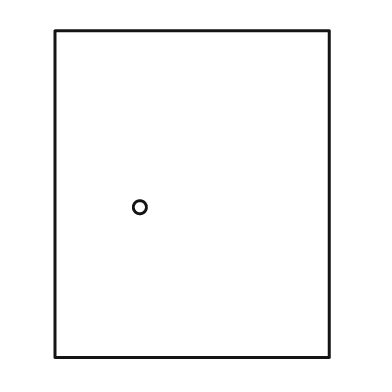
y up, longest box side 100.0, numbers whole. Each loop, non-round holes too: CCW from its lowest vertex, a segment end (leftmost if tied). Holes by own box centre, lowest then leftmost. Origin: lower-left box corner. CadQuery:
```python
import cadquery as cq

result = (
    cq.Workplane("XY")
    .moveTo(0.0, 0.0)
    .lineTo(84.0, 0.0)
    .lineTo(84.0, 100.0)
    .lineTo(0.0, 100.0)
    .close()
    .moveTo(26.0, 46.0)
    .circle(2.0)
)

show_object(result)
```